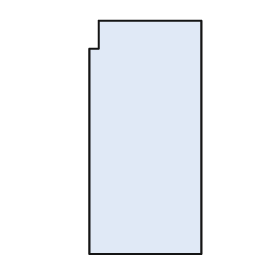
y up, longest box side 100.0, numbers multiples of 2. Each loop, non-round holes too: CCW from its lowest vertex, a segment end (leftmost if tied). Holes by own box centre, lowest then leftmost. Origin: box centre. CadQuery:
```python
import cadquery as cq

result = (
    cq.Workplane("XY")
    .moveTo(-24.0, -50.0)
    .lineTo(24.0, -50.0)
    .lineTo(24.0, 50.0)
    .lineTo(-20.0, 50.0)
    .lineTo(-20.0, 38.0)
    .lineTo(-24.0, 38.0)
    .close()
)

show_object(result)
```